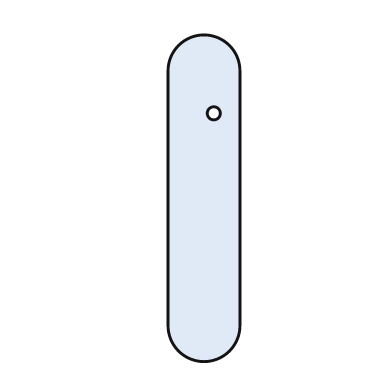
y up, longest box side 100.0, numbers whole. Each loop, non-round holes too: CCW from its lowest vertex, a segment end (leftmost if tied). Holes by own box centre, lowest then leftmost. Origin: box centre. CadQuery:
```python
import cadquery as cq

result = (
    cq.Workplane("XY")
    .moveTo(-11.0, -39.0)
    .threePointArc((0.0, -50.0), (11.0, -39.0))
    .lineTo(11.0, 39.0)
    .threePointArc((0.0, 50.0), (-11.0, 39.0))
    .close()
    .moveTo(3.0, 26.0)
    .circle(2.0)
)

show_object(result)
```